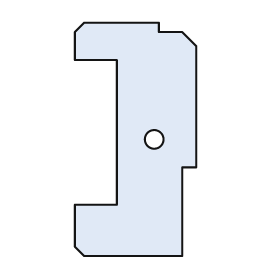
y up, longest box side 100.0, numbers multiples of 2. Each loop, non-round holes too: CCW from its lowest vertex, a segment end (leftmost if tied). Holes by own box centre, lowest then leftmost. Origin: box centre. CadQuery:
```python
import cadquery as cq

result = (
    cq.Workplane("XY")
    .moveTo(-22.0, -50.0)
    .lineTo(20.0, -50.0)
    .lineTo(20.0, -12.0)
    .lineTo(26.0, -12.0)
    .lineTo(26.0, 40.0)
    .lineTo(20.0, 46.0)
    .lineTo(10.0, 46.0)
    .lineTo(10.0, 50.0)
    .lineTo(-22.0, 50.0)
    .lineTo(-26.0, 46.0)
    .lineTo(-26.0, 34.0)
    .lineTo(-8.0, 34.0)
    .lineTo(-8.0, -28.0)
    .lineTo(-26.0, -28.0)
    .lineTo(-26.0, -46.0)
    .close()
    .moveTo(8.0, 0.0)
    .circle(4.0)
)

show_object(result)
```